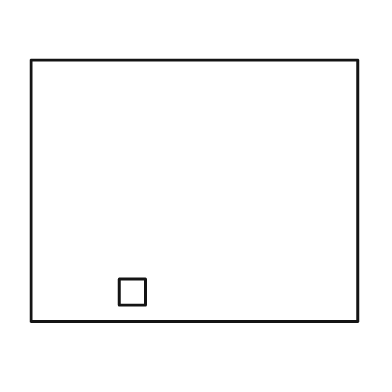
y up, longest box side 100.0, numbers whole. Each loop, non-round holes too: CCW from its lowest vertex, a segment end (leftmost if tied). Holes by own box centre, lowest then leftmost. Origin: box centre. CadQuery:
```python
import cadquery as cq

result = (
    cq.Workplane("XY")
    .moveTo(-50.0, -40.0)
    .lineTo(50.0, -40.0)
    .lineTo(50.0, 40.0)
    .lineTo(-50.0, 40.0)
    .close()
    .moveTo(-23.0, -35.0)
    .lineTo(-15.0, -35.0)
    .lineTo(-15.0, -27.0)
    .lineTo(-23.0, -27.0)
    .close()
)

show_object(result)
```